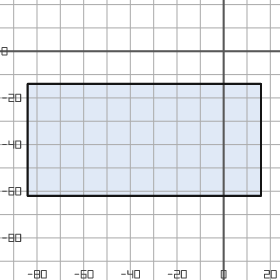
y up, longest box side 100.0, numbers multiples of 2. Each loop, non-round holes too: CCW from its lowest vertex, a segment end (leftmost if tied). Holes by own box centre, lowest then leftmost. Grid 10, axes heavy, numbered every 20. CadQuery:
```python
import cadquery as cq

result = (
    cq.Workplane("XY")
    .moveTo(-84.0, -62.0)
    .lineTo(16.0, -62.0)
    .lineTo(16.0, -14.0)
    .lineTo(-84.0, -14.0)
    .close()
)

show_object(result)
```